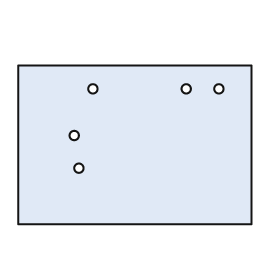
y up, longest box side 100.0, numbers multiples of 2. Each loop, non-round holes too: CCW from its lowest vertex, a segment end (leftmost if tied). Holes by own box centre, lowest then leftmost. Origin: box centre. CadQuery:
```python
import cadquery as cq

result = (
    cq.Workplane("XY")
    .moveTo(-50.0, -34.0)
    .lineTo(50.0, -34.0)
    .lineTo(50.0, 34.0)
    .lineTo(-50.0, 34.0)
    .close()
    .moveTo(-24.0, -10.0)
    .circle(2.0)
    .moveTo(-26.0, 4.0)
    .circle(2.0)
    .moveTo(-18.0, 24.0)
    .circle(2.0)
    .moveTo(22.0, 24.0)
    .circle(2.0)
    .moveTo(36.0, 24.0)
    .circle(2.0)
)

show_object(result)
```